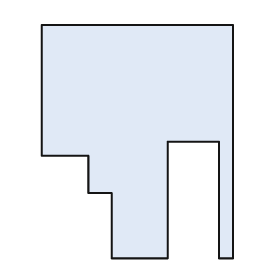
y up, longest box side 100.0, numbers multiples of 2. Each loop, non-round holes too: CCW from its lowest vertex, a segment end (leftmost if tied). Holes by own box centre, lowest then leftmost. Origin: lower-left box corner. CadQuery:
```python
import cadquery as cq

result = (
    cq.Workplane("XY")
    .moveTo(30.0, 0.0)
    .lineTo(54.0, 0.0)
    .lineTo(54.0, 50.0)
    .lineTo(76.0, 50.0)
    .lineTo(76.0, 0.0)
    .lineTo(82.0, 0.0)
    .lineTo(82.0, 100.0)
    .lineTo(0.0, 100.0)
    .lineTo(0.0, 44.0)
    .lineTo(20.0, 44.0)
    .lineTo(20.0, 28.0)
    .lineTo(30.0, 28.0)
    .close()
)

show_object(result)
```